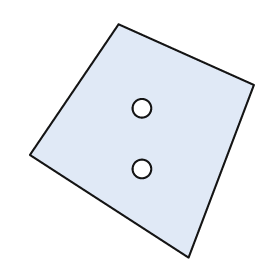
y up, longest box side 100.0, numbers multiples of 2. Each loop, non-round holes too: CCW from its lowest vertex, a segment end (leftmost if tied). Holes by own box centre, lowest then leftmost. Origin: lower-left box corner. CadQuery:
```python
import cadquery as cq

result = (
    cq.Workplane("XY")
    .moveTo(68.0, 0.0)
    .lineTo(96.0, 74.0)
    .lineTo(38.0, 100.0)
    .lineTo(0.0, 44.0)
    .close()
    .moveTo(48.0, 38.0)
    .circle(4.0)
    .moveTo(48.0, 64.0)
    .circle(4.0)
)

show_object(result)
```